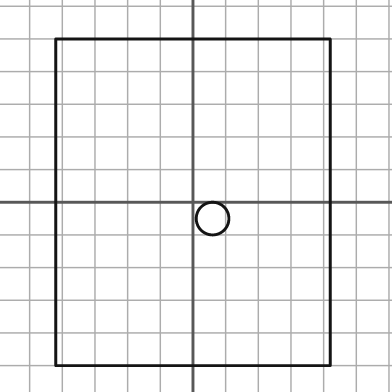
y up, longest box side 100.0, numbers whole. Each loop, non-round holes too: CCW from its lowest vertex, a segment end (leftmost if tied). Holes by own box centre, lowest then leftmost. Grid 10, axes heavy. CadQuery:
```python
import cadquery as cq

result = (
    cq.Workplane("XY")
    .moveTo(-42.0, -50.0)
    .lineTo(42.0, -50.0)
    .lineTo(42.0, 50.0)
    .lineTo(-42.0, 50.0)
    .close()
    .moveTo(6.0, -5.0)
    .circle(5.0)
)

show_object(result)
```